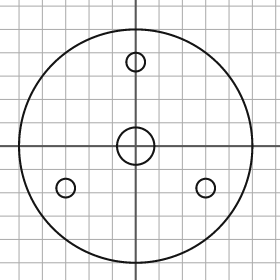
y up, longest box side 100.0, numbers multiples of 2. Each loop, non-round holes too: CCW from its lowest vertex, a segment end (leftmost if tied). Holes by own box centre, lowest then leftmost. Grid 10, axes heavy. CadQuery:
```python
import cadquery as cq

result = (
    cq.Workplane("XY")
    .moveTo(0.0, 0.0)
    .circle(50.0)
    .moveTo(-30.0, -18.0)
    .circle(4.0)
    .moveTo(30.0, -18.0)
    .circle(4.0)
    .moveTo(0.0, 0.0)
    .circle(8.0)
    .moveTo(0.0, 36.0)
    .circle(4.0)
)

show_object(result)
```